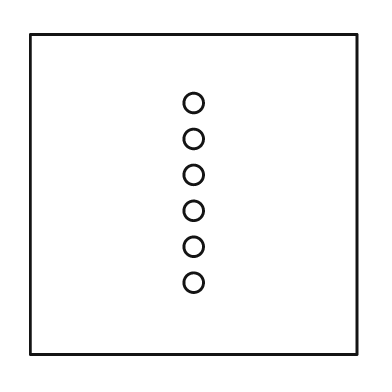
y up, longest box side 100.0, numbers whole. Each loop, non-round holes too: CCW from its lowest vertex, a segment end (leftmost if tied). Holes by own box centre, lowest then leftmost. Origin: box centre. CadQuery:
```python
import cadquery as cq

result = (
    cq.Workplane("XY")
    .moveTo(-50.0, -49.0)
    .lineTo(50.0, -49.0)
    .lineTo(50.0, 49.0)
    .lineTo(-50.0, 49.0)
    .close()
    .moveTo(0.0, -27.0)
    .circle(3.0)
    .moveTo(0.0, -16.0)
    .circle(3.0)
    .moveTo(0.0, -5.0)
    .circle(3.0)
    .moveTo(0.0, 6.0)
    .circle(3.0)
    .moveTo(0.0, 17.0)
    .circle(3.0)
    .moveTo(0.0, 28.0)
    .circle(3.0)
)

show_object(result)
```